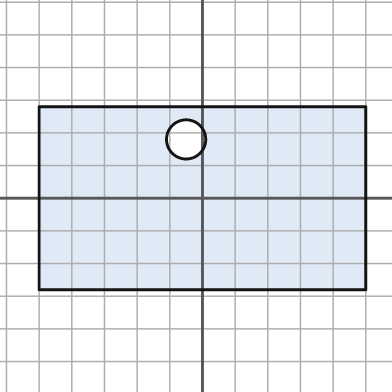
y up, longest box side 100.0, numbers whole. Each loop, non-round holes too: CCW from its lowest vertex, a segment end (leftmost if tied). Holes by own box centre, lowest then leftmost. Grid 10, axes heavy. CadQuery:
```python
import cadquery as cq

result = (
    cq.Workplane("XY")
    .moveTo(-50.0, -28.0)
    .lineTo(50.0, -28.0)
    .lineTo(50.0, 28.0)
    .lineTo(-50.0, 28.0)
    .close()
    .moveTo(-5.0, 18.0)
    .circle(6.0)
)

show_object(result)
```